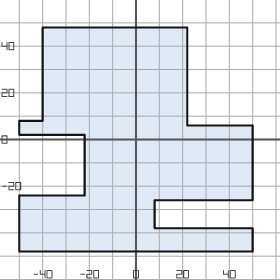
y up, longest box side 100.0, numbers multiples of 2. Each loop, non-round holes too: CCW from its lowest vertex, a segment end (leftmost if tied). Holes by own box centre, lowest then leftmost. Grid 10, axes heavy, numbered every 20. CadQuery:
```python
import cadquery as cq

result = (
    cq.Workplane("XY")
    .moveTo(-50.0, -48.0)
    .lineTo(50.0, -48.0)
    .lineTo(50.0, -38.0)
    .lineTo(8.0, -38.0)
    .lineTo(8.0, -26.0)
    .lineTo(50.0, -26.0)
    .lineTo(50.0, 6.0)
    .lineTo(22.0, 6.0)
    .lineTo(22.0, 48.0)
    .lineTo(-40.0, 48.0)
    .lineTo(-40.0, 8.0)
    .lineTo(-50.0, 8.0)
    .lineTo(-50.0, 2.0)
    .lineTo(-22.0, 2.0)
    .lineTo(-22.0, -24.0)
    .lineTo(-50.0, -24.0)
    .close()
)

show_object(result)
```